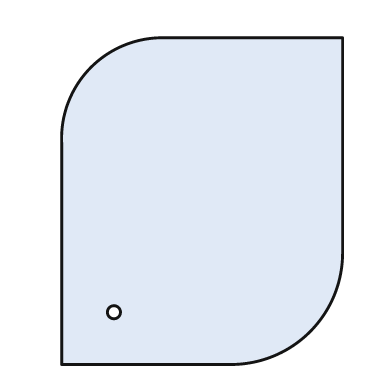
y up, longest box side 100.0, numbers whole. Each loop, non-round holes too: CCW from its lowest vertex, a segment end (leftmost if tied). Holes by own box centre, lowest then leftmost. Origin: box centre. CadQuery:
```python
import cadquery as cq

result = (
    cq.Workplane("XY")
    .moveTo(-43.0, -50.0)
    .lineTo(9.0, -50.0)
    .threePointArc((33.0, -40.0), (43.0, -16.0))
    .lineTo(43.0, 50.0)
    .lineTo(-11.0, 50.0)
    .threePointArc((-34.0, 41.0), (-43.0, 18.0))
    .close()
    .moveTo(-27.0, -34.0)
    .circle(2.0)
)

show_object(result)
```